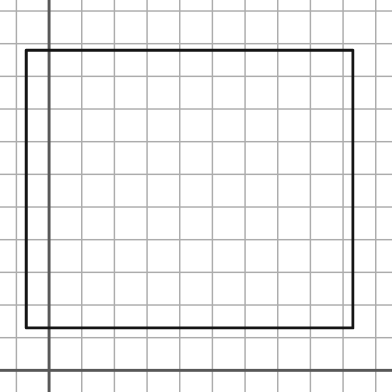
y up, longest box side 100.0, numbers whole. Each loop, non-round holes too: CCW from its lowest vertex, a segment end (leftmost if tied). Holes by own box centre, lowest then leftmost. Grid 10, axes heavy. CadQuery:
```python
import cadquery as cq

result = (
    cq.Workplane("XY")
    .moveTo(-7.0, 13.0)
    .lineTo(93.0, 13.0)
    .lineTo(93.0, 98.0)
    .lineTo(-7.0, 98.0)
    .close()
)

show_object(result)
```